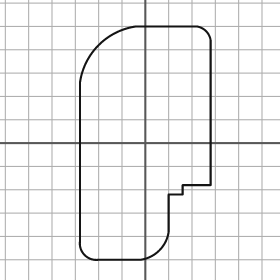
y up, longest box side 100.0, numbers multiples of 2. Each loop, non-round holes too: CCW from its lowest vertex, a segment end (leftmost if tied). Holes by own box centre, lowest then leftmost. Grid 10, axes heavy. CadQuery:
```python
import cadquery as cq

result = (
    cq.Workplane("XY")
    .moveTo(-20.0, -50.0)
    .lineTo(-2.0, -50.0)
    .threePointArc((6.0, -46.0), (10.0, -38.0))
    .lineTo(10.0, -22.0)
    .lineTo(16.0, -22.0)
    .lineTo(16.0, -18.0)
    .lineTo(28.0, -18.0)
    .lineTo(28.0, 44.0)
    .threePointArc((26.0, 48.0), (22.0, 50.0))
    .lineTo(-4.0, 50.0)
    .threePointArc((-20.0, 42.0), (-28.0, 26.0))
    .lineTo(-28.0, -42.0)
    .threePointArc((-26.0, -48.0), (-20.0, -50.0))
    .close()
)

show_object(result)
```